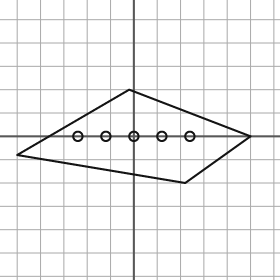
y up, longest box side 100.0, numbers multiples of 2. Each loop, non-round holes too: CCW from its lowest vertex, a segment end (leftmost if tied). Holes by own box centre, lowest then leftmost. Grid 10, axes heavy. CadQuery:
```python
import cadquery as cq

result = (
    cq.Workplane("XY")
    .moveTo(22.0, -20.0)
    .lineTo(50.0, 0.0)
    .lineTo(-2.0, 20.0)
    .lineTo(-50.0, -8.0)
    .close()
    .moveTo(-24.0, 0.0)
    .circle(2.0)
    .moveTo(-12.0, 0.0)
    .circle(2.0)
    .moveTo(0.0, 0.0)
    .circle(2.0)
    .moveTo(12.0, 0.0)
    .circle(2.0)
    .moveTo(24.0, 0.0)
    .circle(2.0)
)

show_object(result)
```